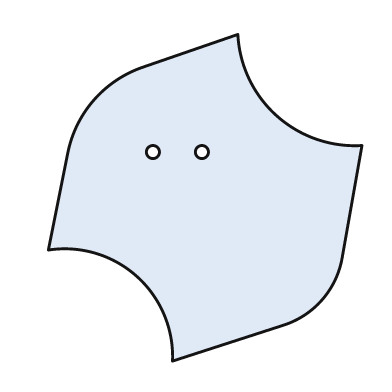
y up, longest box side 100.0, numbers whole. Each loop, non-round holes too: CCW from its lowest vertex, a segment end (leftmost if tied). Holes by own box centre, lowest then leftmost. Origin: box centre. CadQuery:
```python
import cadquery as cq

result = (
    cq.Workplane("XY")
    .moveTo(-10.0, -50.0)
    .lineTo(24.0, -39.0)
    .threePointArc((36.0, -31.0), (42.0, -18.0))
    .lineTo(48.0, 16.0)
    .threePointArc((22.0, 25.0), (10.0, 50.0))
    .lineTo(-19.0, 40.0)
    .threePointArc((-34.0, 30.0), (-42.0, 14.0))
    .lineTo(-48.0, -16.0)
    .threePointArc((-21.0, -24.0), (-10.0, -50.0))
    .close()
    .moveTo(-16.0, 14.0)
    .circle(2.0)
    .moveTo(-1.0, 14.0)
    .circle(2.0)
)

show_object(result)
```